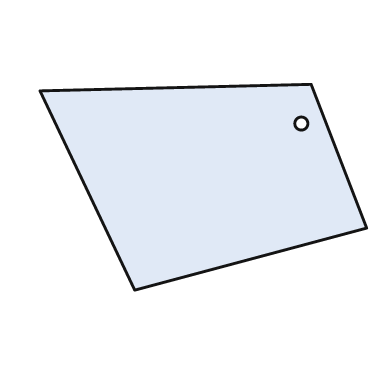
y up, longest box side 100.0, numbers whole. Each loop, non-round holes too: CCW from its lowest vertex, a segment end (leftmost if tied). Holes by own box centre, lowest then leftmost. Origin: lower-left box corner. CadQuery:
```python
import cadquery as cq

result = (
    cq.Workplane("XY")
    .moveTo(29.0, 0.0)
    .lineTo(100.0, 19.0)
    .lineTo(83.0, 63.0)
    .lineTo(0.0, 61.0)
    .close()
    .moveTo(80.0, 51.0)
    .circle(2.0)
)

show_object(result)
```